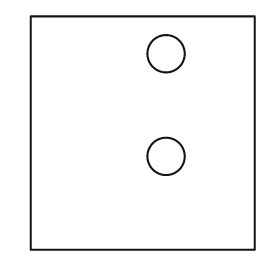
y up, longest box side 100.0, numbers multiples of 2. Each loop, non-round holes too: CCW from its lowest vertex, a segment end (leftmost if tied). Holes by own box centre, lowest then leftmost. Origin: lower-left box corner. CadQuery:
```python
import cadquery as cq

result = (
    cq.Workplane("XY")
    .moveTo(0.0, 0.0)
    .lineTo(96.0, 0.0)
    .lineTo(96.0, 100.0)
    .lineTo(0.0, 100.0)
    .close()
    .moveTo(58.0, 40.0)
    .circle(8.0)
    .moveTo(58.0, 84.0)
    .circle(8.0)
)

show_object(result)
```